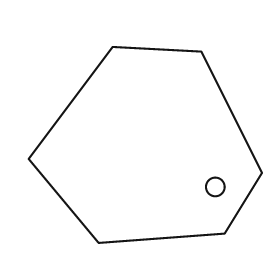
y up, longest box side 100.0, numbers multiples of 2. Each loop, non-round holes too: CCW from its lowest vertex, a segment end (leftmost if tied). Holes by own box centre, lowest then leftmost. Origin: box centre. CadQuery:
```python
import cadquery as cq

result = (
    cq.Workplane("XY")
    .moveTo(-20.0, -42.0)
    .lineTo(34.0, -38.0)
    .lineTo(50.0, -12.0)
    .lineTo(24.0, 40.0)
    .lineTo(-14.0, 42.0)
    .lineTo(-50.0, -6.0)
    .close()
    .moveTo(30.0, -18.0)
    .circle(4.0)
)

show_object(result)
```